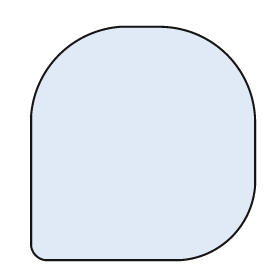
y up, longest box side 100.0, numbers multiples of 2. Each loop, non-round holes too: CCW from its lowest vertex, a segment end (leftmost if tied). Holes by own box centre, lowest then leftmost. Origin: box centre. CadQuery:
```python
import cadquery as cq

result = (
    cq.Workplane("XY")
    .moveTo(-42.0, -50.0)
    .lineTo(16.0, -50.0)
    .threePointArc((38.0, -40.0), (48.0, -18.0))
    .lineTo(48.0, 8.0)
    .threePointArc((36.0, 38.0), (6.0, 50.0))
    .lineTo(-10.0, 50.0)
    .threePointArc((-36.0, 38.0), (-48.0, 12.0))
    .lineTo(-48.0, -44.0)
    .threePointArc((-46.0, -48.0), (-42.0, -50.0))
    .close()
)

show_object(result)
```